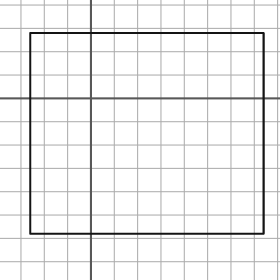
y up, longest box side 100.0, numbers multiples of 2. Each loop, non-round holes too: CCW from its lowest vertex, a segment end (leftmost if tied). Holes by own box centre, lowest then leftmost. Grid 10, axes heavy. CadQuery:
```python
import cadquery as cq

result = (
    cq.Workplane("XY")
    .moveTo(-26.0, -58.0)
    .lineTo(74.0, -58.0)
    .lineTo(74.0, 28.0)
    .lineTo(-26.0, 28.0)
    .close()
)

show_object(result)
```